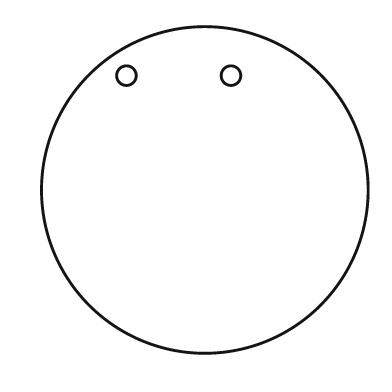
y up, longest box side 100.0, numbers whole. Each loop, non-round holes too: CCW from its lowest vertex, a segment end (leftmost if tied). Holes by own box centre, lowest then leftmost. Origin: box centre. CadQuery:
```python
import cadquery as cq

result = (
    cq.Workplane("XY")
    .moveTo(0.0, 0.0)
    .circle(50.0)
    .moveTo(-24.0, 35.0)
    .circle(3.0)
    .moveTo(8.0, 35.0)
    .circle(3.0)
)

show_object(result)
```